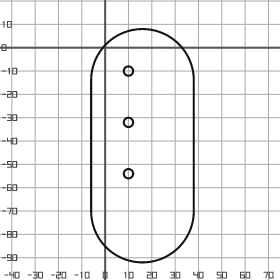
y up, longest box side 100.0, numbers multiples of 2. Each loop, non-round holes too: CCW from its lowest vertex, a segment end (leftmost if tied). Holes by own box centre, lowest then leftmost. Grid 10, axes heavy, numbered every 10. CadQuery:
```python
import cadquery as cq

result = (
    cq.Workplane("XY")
    .moveTo(-6.0, -70.0)
    .threePointArc((16.0, -92.0), (38.0, -70.0))
    .lineTo(38.0, -14.0)
    .threePointArc((16.0, 8.0), (-6.0, -14.0))
    .close()
    .moveTo(10.0, -54.0)
    .circle(2.0)
    .moveTo(10.0, -32.0)
    .circle(2.0)
    .moveTo(10.0, -10.0)
    .circle(2.0)
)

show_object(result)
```